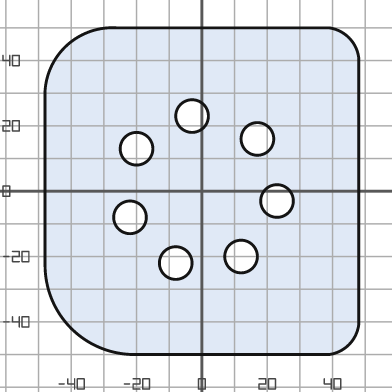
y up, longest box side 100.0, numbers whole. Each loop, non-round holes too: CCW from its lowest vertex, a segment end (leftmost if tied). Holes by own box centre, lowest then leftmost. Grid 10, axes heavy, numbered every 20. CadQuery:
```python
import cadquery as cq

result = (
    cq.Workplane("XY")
    .moveTo(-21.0, -50.0)
    .lineTo(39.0, -50.0)
    .threePointArc((45.0, -47.0), (48.0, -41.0))
    .lineTo(48.0, 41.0)
    .threePointArc((45.0, 47.0), (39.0, 50.0))
    .lineTo(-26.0, 50.0)
    .threePointArc((-42.0, 44.0), (-48.0, 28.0))
    .lineTo(-48.0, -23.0)
    .threePointArc((-40.0, -42.0), (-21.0, -50.0))
    .close()
    .moveTo(-8.0, -22.0)
    .circle(5.0)
    .moveTo(12.0, -20.0)
    .circle(5.0)
    .moveTo(-22.0, -8.0)
    .circle(5.0)
    .moveTo(23.0, -3.0)
    .circle(5.0)
    .moveTo(-20.0, 13.0)
    .circle(5.0)
    .moveTo(17.0, 16.0)
    .circle(5.0)
    .moveTo(-3.0, 23.0)
    .circle(5.0)
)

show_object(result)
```